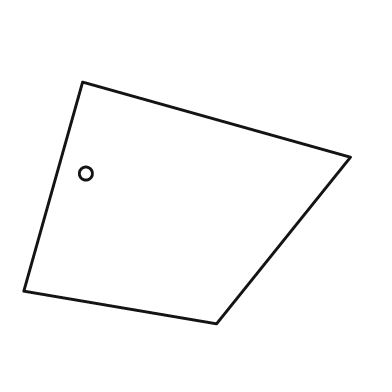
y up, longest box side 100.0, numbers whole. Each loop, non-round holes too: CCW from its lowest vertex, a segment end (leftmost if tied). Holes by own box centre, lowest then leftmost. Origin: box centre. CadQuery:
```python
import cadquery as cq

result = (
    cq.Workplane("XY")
    .moveTo(9.0, -37.0)
    .lineTo(50.0, 14.0)
    .lineTo(-32.0, 37.0)
    .lineTo(-50.0, -27.0)
    .close()
    .moveTo(-31.0, 9.0)
    .circle(2.0)
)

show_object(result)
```